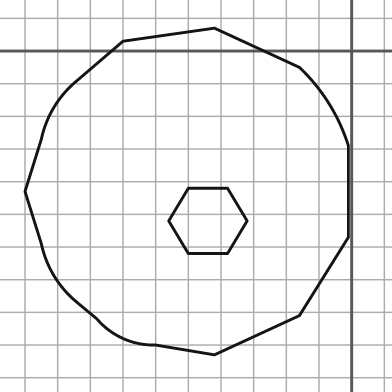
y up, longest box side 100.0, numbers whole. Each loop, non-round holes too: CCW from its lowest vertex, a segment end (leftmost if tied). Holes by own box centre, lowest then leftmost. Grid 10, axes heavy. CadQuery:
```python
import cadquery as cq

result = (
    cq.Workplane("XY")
    .moveTo(-42.0, -93.0)
    .lineTo(-16.0, -81.0)
    .lineTo(-1.0, -57.0)
    .lineTo(-1.0, -29.0)
    .threePointArc((-7.0, -16.0), (-16.0, -5.0))
    .lineTo(-42.0, 7.0)
    .lineTo(-70.0, 3.0)
    .lineTo(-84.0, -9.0)
    .threePointArc((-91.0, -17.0), (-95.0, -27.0))
    .lineTo(-100.0, -43.0)
    .lineTo(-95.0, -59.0)
    .threePointArc((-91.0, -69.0), (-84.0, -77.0))
    .lineTo(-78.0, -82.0)
    .threePointArc((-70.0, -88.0), (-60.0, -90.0))
    .close()
    .moveTo(-50.0, -62.0)
    .lineTo(-38.0, -62.0)
    .lineTo(-32.0, -52.0)
    .lineTo(-38.0, -42.0)
    .lineTo(-50.0, -42.0)
    .lineTo(-56.0, -52.0)
    .close()
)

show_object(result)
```